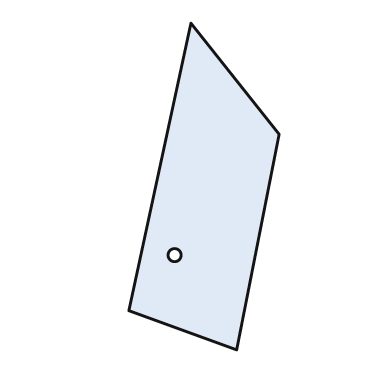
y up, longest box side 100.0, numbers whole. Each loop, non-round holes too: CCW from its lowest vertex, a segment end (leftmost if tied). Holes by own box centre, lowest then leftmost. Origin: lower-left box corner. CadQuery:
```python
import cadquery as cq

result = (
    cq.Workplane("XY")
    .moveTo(33.0, 0.0)
    .lineTo(46.0, 66.0)
    .lineTo(19.0, 100.0)
    .lineTo(0.0, 12.0)
    .close()
    .moveTo(14.0, 29.0)
    .circle(2.0)
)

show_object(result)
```